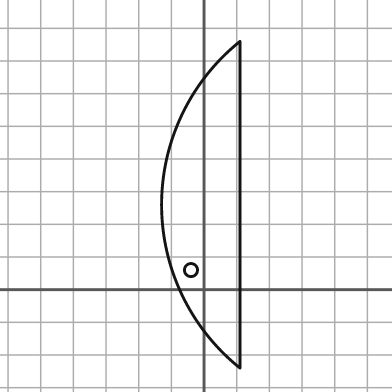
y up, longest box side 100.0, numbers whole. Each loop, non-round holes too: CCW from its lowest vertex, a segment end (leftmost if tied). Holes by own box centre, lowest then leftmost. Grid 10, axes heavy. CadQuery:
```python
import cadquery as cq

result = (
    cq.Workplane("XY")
    .moveTo(11.0, -24.0)
    .lineTo(11.0, 76.0)
    .threePointArc((-13.0, 26.0), (11.0, -24.0))
    .close()
    .moveTo(-4.0, 6.0)
    .circle(2.0)
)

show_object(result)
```